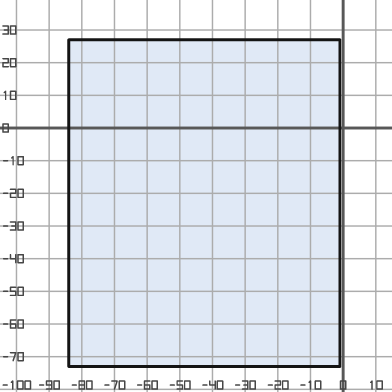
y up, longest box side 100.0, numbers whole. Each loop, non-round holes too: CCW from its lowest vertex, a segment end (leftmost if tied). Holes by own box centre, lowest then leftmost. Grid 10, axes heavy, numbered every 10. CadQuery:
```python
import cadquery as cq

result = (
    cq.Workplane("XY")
    .moveTo(-84.0, -73.0)
    .lineTo(-1.0, -73.0)
    .lineTo(-1.0, 27.0)
    .lineTo(-84.0, 27.0)
    .close()
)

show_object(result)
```